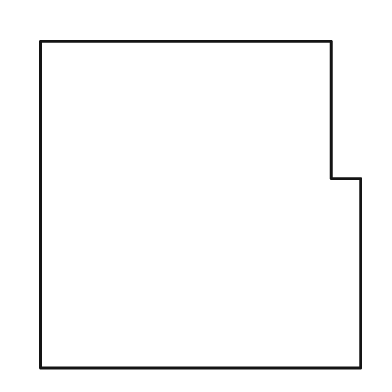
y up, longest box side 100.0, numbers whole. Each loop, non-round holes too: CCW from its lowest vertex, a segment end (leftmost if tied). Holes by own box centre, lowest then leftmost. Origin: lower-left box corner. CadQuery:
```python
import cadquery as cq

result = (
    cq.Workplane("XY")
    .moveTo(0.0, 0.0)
    .lineTo(98.0, 0.0)
    .lineTo(98.0, 58.0)
    .lineTo(89.0, 58.0)
    .lineTo(89.0, 100.0)
    .lineTo(0.0, 100.0)
    .close()
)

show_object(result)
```